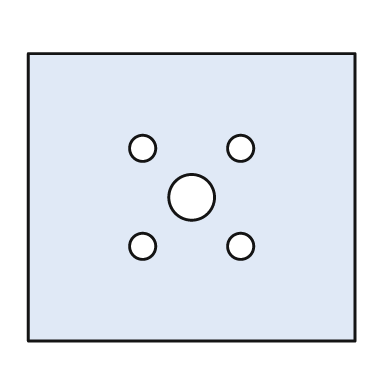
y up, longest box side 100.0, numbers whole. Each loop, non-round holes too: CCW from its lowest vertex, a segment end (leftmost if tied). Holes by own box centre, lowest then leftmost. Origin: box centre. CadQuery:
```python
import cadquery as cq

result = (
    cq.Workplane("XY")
    .moveTo(-50.0, -44.0)
    .lineTo(50.0, -44.0)
    .lineTo(50.0, 44.0)
    .lineTo(-50.0, 44.0)
    .close()
    .moveTo(-15.0, -15.0)
    .circle(4.0)
    .moveTo(15.0, -15.0)
    .circle(4.0)
    .moveTo(0.0, 0.0)
    .circle(7.0)
    .moveTo(-15.0, 15.0)
    .circle(4.0)
    .moveTo(15.0, 15.0)
    .circle(4.0)
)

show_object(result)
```